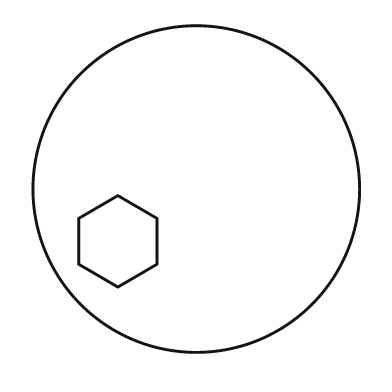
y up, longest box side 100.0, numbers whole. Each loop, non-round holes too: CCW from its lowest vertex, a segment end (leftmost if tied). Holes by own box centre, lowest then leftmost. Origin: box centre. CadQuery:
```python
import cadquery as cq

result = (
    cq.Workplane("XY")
    .moveTo(0.0, 0.0)
    .circle(50.0)
    .moveTo(-24.0, -30.0)
    .lineTo(-12.0, -23.0)
    .lineTo(-12.0, -9.0)
    .lineTo(-24.0, -2.0)
    .lineTo(-36.0, -9.0)
    .lineTo(-36.0, -23.0)
    .close()
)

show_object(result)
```